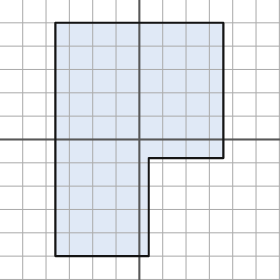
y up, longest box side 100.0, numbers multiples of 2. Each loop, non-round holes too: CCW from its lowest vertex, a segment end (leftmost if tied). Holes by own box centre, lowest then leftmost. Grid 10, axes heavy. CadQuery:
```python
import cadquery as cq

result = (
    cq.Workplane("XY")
    .moveTo(-36.0, -50.0)
    .lineTo(4.0, -50.0)
    .lineTo(4.0, -8.0)
    .lineTo(36.0, -8.0)
    .lineTo(36.0, 50.0)
    .lineTo(-36.0, 50.0)
    .close()
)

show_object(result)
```